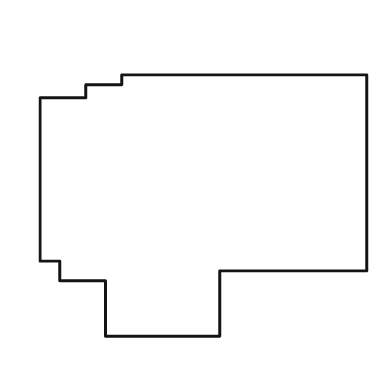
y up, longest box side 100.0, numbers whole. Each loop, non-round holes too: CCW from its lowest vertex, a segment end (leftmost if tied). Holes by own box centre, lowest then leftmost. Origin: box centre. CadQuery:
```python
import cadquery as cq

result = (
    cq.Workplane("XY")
    .moveTo(-30.0, -40.0)
    .lineTo(5.0, -40.0)
    .lineTo(5.0, -20.0)
    .lineTo(50.0, -20.0)
    .lineTo(50.0, 40.0)
    .lineTo(-25.0, 40.0)
    .lineTo(-25.0, 37.0)
    .lineTo(-36.0, 37.0)
    .lineTo(-36.0, 33.0)
    .lineTo(-50.0, 33.0)
    .lineTo(-50.0, -17.0)
    .lineTo(-44.0, -17.0)
    .lineTo(-44.0, -23.0)
    .lineTo(-30.0, -23.0)
    .close()
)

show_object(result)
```